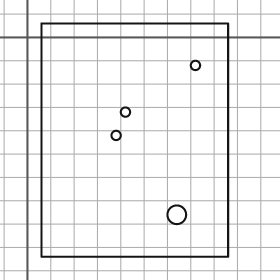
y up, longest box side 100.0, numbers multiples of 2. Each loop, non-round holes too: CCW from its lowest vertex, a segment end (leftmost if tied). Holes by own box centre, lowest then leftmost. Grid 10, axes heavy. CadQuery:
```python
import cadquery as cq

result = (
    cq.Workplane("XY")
    .moveTo(6.0, -94.0)
    .lineTo(86.0, -94.0)
    .lineTo(86.0, 6.0)
    .lineTo(6.0, 6.0)
    .close()
    .moveTo(64.0, -76.0)
    .circle(4.0)
    .moveTo(38.0, -42.0)
    .circle(2.0)
    .moveTo(42.0, -32.0)
    .circle(2.0)
    .moveTo(72.0, -12.0)
    .circle(2.0)
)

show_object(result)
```